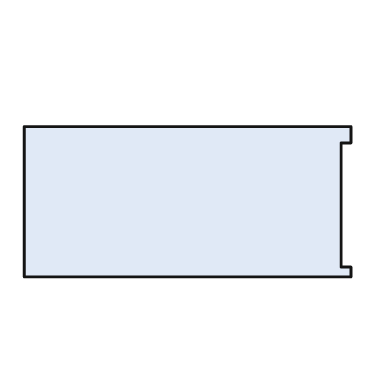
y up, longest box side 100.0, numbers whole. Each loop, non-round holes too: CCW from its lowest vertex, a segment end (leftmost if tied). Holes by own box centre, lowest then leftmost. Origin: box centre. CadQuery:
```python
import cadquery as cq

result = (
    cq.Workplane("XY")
    .moveTo(-50.0, -23.0)
    .lineTo(50.0, -23.0)
    .lineTo(50.0, -20.0)
    .lineTo(47.0, -20.0)
    .lineTo(47.0, 18.0)
    .lineTo(50.0, 18.0)
    .lineTo(50.0, 23.0)
    .lineTo(-50.0, 23.0)
    .close()
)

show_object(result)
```